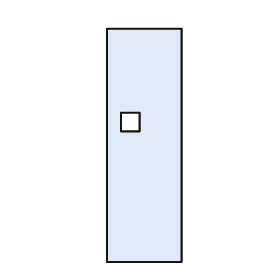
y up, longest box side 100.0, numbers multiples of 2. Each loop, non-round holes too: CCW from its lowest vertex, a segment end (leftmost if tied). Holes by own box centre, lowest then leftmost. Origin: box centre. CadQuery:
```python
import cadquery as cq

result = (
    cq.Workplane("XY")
    .moveTo(-16.0, -50.0)
    .lineTo(16.0, -50.0)
    .lineTo(16.0, 50.0)
    .lineTo(-16.0, 50.0)
    .close()
    .moveTo(-10.0, 6.0)
    .lineTo(-2.0, 6.0)
    .lineTo(-2.0, 14.0)
    .lineTo(-10.0, 14.0)
    .close()
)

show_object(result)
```